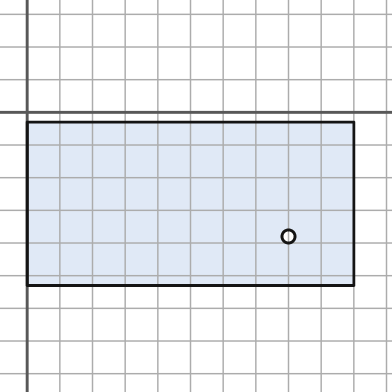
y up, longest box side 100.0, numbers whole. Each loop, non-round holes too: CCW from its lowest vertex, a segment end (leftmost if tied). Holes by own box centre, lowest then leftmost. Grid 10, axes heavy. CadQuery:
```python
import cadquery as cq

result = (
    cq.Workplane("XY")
    .moveTo(0.0, -53.0)
    .lineTo(100.0, -53.0)
    .lineTo(100.0, -3.0)
    .lineTo(0.0, -3.0)
    .close()
    .moveTo(80.0, -38.0)
    .circle(2.0)
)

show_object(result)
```